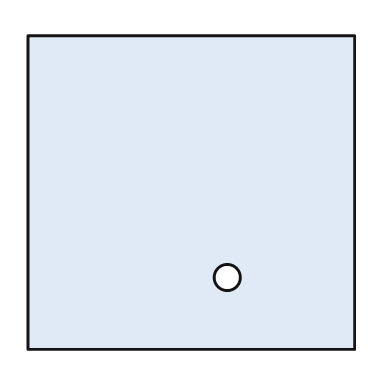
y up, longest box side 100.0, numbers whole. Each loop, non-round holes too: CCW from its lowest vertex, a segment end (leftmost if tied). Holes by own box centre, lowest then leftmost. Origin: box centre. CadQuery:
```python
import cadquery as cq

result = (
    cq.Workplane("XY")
    .moveTo(-50.0, -48.0)
    .lineTo(50.0, -48.0)
    .lineTo(50.0, 48.0)
    .lineTo(-50.0, 48.0)
    .close()
    .moveTo(11.0, -26.0)
    .circle(4.0)
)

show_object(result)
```